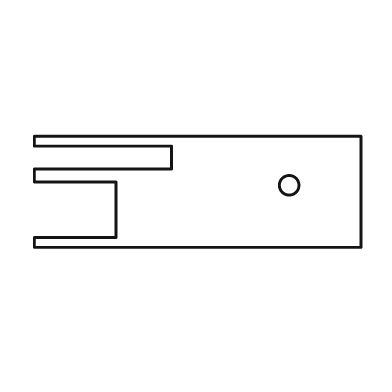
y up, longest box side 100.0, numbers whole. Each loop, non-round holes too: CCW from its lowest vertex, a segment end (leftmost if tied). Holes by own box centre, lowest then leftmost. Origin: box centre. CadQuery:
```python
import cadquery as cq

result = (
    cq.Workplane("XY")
    .moveTo(-50.0, -17.0)
    .lineTo(50.0, -17.0)
    .lineTo(50.0, 17.0)
    .lineTo(-50.0, 17.0)
    .lineTo(-50.0, 14.0)
    .lineTo(-8.0, 14.0)
    .lineTo(-8.0, 7.0)
    .lineTo(-50.0, 7.0)
    .lineTo(-50.0, 3.0)
    .lineTo(-25.0, 3.0)
    .lineTo(-25.0, -14.0)
    .lineTo(-50.0, -14.0)
    .close()
    .moveTo(28.0, 2.0)
    .circle(3.0)
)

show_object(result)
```